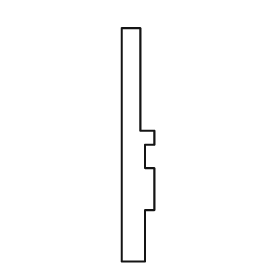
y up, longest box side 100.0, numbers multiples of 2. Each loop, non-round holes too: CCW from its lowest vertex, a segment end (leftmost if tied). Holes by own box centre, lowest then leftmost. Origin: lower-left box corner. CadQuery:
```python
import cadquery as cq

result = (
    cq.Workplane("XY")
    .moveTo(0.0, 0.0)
    .lineTo(10.0, 0.0)
    .lineTo(10.0, 22.0)
    .lineTo(14.0, 22.0)
    .lineTo(14.0, 40.0)
    .lineTo(10.0, 40.0)
    .lineTo(10.0, 50.0)
    .lineTo(14.0, 50.0)
    .lineTo(14.0, 56.0)
    .lineTo(8.0, 56.0)
    .lineTo(8.0, 100.0)
    .lineTo(0.0, 100.0)
    .close()
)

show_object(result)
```